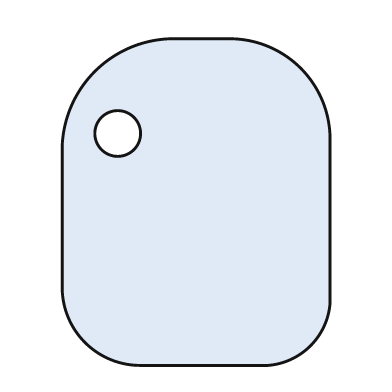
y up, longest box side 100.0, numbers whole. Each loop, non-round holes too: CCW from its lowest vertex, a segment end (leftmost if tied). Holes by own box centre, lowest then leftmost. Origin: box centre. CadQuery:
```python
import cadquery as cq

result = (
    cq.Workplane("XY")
    .moveTo(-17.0, -50.0)
    .lineTo(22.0, -50.0)
    .threePointArc((35.0, -44.0), (41.0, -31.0))
    .lineTo(41.0, 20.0)
    .threePointArc((32.0, 41.0), (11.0, 50.0))
    .lineTo(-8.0, 50.0)
    .threePointArc((-31.0, 40.0), (-41.0, 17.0))
    .lineTo(-41.0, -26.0)
    .threePointArc((-34.0, -43.0), (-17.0, -50.0))
    .close()
    .moveTo(-24.0, 21.0)
    .circle(7.0)
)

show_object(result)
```